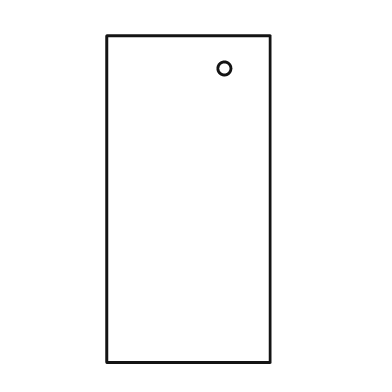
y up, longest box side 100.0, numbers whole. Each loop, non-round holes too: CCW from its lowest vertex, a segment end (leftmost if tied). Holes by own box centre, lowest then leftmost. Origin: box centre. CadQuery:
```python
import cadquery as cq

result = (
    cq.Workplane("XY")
    .moveTo(-25.0, -50.0)
    .lineTo(25.0, -50.0)
    .lineTo(25.0, 50.0)
    .lineTo(-25.0, 50.0)
    .close()
    .moveTo(11.0, 40.0)
    .circle(2.0)
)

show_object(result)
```